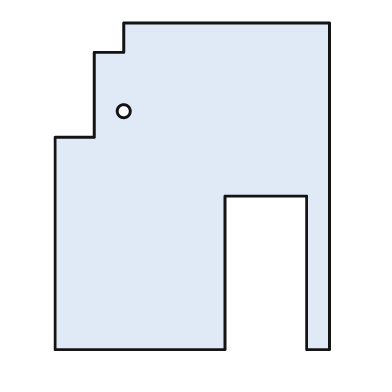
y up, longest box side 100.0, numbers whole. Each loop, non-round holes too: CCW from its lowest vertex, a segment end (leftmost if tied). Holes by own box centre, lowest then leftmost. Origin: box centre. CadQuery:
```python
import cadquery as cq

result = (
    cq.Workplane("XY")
    .moveTo(-42.0, -50.0)
    .lineTo(10.0, -50.0)
    .lineTo(10.0, -3.0)
    .lineTo(35.0, -3.0)
    .lineTo(35.0, -50.0)
    .lineTo(42.0, -50.0)
    .lineTo(42.0, 50.0)
    .lineTo(-21.0, 50.0)
    .lineTo(-21.0, 41.0)
    .lineTo(-30.0, 41.0)
    .lineTo(-30.0, 15.0)
    .lineTo(-42.0, 15.0)
    .close()
    .moveTo(-21.0, 23.0)
    .circle(2.0)
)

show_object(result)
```